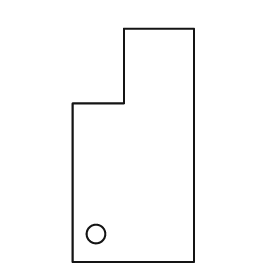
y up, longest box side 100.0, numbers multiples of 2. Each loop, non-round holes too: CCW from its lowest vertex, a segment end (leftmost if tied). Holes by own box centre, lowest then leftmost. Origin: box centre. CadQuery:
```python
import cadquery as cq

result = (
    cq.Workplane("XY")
    .moveTo(-26.0, -50.0)
    .lineTo(26.0, -50.0)
    .lineTo(26.0, 50.0)
    .lineTo(-4.0, 50.0)
    .lineTo(-4.0, 18.0)
    .lineTo(-26.0, 18.0)
    .close()
    .moveTo(-16.0, -38.0)
    .circle(4.0)
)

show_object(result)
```